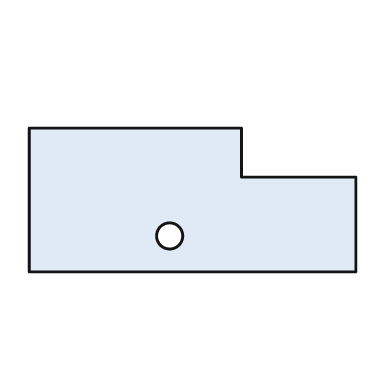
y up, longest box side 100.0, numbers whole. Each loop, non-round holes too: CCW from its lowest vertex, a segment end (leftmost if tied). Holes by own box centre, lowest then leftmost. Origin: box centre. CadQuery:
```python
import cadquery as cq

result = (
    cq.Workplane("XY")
    .moveTo(-50.0, -22.0)
    .lineTo(50.0, -22.0)
    .lineTo(50.0, 7.0)
    .lineTo(15.0, 7.0)
    .lineTo(15.0, 22.0)
    .lineTo(-50.0, 22.0)
    .close()
    .moveTo(-7.0, -11.0)
    .circle(4.0)
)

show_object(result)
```